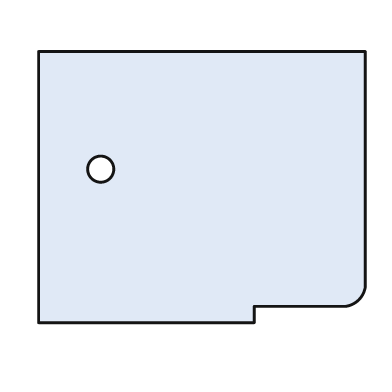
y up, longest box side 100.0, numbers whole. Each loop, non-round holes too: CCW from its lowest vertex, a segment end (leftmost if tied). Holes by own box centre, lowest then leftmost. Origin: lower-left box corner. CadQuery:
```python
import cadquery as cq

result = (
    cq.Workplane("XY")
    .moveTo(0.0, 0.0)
    .lineTo(66.0, 0.0)
    .lineTo(66.0, 5.0)
    .lineTo(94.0, 5.0)
    .threePointArc((98.0, 7.0), (100.0, 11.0))
    .lineTo(100.0, 83.0)
    .lineTo(0.0, 83.0)
    .close()
    .moveTo(19.0, 47.0)
    .circle(4.0)
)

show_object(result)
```